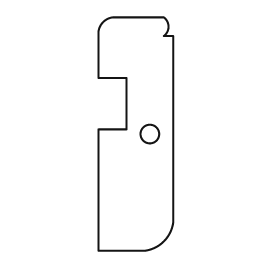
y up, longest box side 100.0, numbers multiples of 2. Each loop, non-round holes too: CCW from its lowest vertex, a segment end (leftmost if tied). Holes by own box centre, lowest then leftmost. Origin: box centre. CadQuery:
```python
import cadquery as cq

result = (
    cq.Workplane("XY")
    .moveTo(-16.0, -50.0)
    .lineTo(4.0, -50.0)
    .threePointArc((12.0, -46.0), (16.0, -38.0))
    .lineTo(16.0, 42.0)
    .lineTo(12.0, 42.0)
    .threePointArc((14.0, 46.0), (12.0, 50.0))
    .lineTo(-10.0, 50.0)
    .threePointArc((-14.0, 48.0), (-16.0, 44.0))
    .lineTo(-16.0, 24.0)
    .lineTo(-4.0, 24.0)
    .lineTo(-4.0, 2.0)
    .lineTo(-16.0, 2.0)
    .close()
    .moveTo(6.0, 0.0)
    .circle(4.0)
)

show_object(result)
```